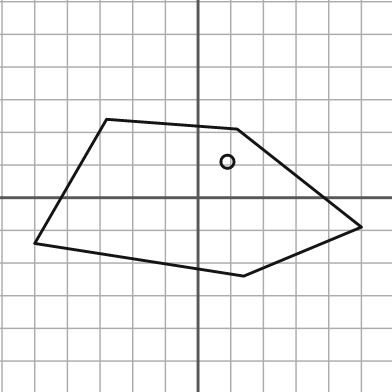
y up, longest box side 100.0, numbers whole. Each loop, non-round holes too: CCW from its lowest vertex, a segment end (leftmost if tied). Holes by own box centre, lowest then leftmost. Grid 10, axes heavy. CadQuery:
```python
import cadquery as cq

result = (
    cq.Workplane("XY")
    .moveTo(14.0, -24.0)
    .lineTo(50.0, -9.0)
    .lineTo(12.0, 21.0)
    .lineTo(-28.0, 24.0)
    .lineTo(-50.0, -14.0)
    .close()
    .moveTo(9.0, 11.0)
    .circle(2.0)
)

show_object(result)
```